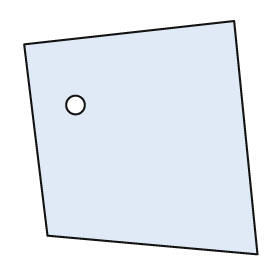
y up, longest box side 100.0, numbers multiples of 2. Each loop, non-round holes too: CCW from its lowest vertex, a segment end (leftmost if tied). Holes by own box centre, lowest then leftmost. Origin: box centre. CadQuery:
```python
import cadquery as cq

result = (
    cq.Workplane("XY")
    .moveTo(50.0, -50.0)
    .lineTo(40.0, 50.0)
    .lineTo(-50.0, 40.0)
    .lineTo(-40.0, -42.0)
    .close()
    .moveTo(-28.0, 14.0)
    .circle(4.0)
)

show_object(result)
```